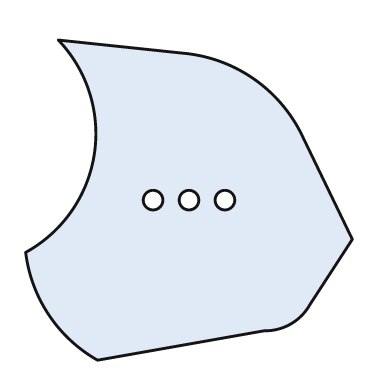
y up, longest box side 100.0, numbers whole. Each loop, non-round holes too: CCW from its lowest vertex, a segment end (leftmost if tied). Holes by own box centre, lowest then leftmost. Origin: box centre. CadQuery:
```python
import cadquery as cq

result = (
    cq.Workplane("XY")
    .moveTo(-28.0, -49.0)
    .lineTo(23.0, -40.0)
    .threePointArc((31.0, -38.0), (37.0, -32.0))
    .lineTo(50.0, -12.0)
    .lineTo(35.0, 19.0)
    .threePointArc((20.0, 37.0), (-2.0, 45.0))
    .lineTo(-40.0, 49.0)
    .threePointArc((-29.0, 14.0), (-50.0, -16.0))
    .threePointArc((-43.0, -35.0), (-28.0, -49.0))
    .close()
    .moveTo(-11.0, 0.0)
    .circle(3.0)
    .moveTo(0.0, 0.0)
    .circle(3.0)
    .moveTo(11.0, 0.0)
    .circle(3.0)
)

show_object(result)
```